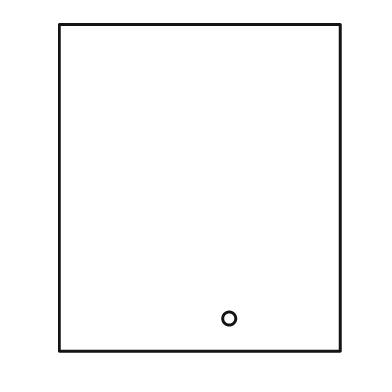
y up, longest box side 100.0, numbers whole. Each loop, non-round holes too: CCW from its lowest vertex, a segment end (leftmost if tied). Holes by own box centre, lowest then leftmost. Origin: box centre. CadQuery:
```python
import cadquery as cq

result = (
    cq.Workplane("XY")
    .moveTo(-43.0, -50.0)
    .lineTo(43.0, -50.0)
    .lineTo(43.0, 50.0)
    .lineTo(-43.0, 50.0)
    .close()
    .moveTo(9.0, -40.0)
    .circle(2.0)
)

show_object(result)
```